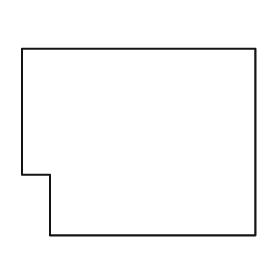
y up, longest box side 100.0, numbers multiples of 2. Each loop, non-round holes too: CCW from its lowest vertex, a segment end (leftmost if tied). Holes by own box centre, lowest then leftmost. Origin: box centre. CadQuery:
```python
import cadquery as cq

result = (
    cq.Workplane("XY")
    .moveTo(-38.0, -40.0)
    .lineTo(50.0, -40.0)
    .lineTo(50.0, 40.0)
    .lineTo(-50.0, 40.0)
    .lineTo(-50.0, -14.0)
    .lineTo(-38.0, -14.0)
    .close()
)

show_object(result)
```